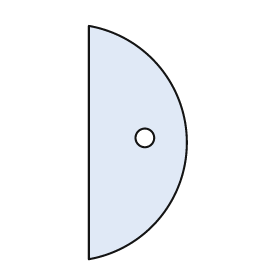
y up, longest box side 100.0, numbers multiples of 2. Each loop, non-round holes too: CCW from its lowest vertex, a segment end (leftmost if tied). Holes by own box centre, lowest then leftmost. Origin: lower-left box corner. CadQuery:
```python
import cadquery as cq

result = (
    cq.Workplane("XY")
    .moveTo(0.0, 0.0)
    .threePointArc((42.0, 50.0), (0.0, 100.0))
    .close()
    .moveTo(24.0, 52.0)
    .circle(4.0)
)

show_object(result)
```